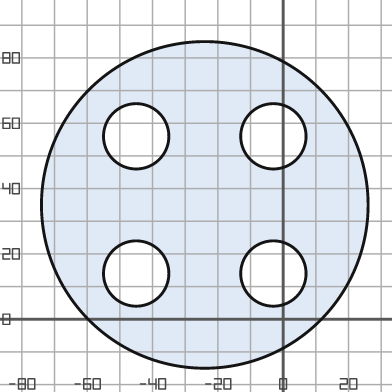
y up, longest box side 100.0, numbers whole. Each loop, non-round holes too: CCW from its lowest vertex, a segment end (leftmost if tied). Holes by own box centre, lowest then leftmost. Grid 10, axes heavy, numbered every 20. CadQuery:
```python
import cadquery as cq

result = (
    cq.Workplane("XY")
    .moveTo(-24.0, 35.0)
    .circle(50.0)
    .moveTo(-45.0, 14.0)
    .circle(10.0)
    .moveTo(-3.0, 14.0)
    .circle(10.0)
    .moveTo(-45.0, 56.0)
    .circle(10.0)
    .moveTo(-3.0, 56.0)
    .circle(10.0)
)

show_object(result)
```